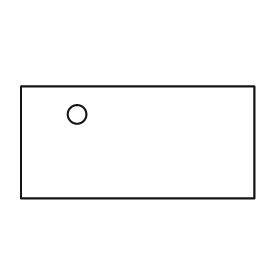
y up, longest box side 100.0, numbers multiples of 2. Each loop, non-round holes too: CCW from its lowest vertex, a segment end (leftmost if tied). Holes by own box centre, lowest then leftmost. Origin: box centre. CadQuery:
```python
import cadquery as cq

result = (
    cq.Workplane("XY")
    .moveTo(-50.0, -24.0)
    .lineTo(50.0, -24.0)
    .lineTo(50.0, 24.0)
    .lineTo(-50.0, 24.0)
    .close()
    .moveTo(-26.0, 12.0)
    .circle(4.0)
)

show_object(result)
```